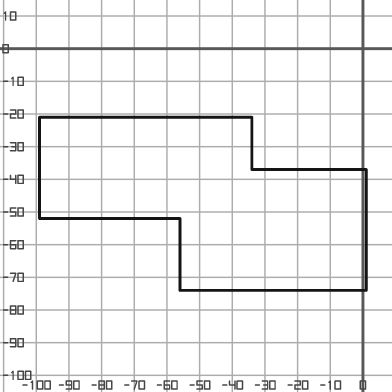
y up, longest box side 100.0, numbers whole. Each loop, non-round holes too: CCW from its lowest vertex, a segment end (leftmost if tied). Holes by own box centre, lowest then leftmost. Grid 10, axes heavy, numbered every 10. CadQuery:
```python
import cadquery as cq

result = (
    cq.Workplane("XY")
    .moveTo(-56.0, -74.0)
    .lineTo(1.0, -74.0)
    .lineTo(1.0, -37.0)
    .lineTo(-34.0, -37.0)
    .lineTo(-34.0, -21.0)
    .lineTo(-99.0, -21.0)
    .lineTo(-99.0, -52.0)
    .lineTo(-56.0, -52.0)
    .close()
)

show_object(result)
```